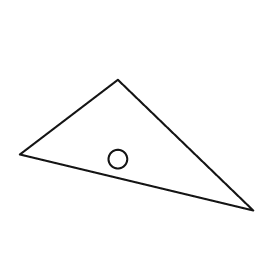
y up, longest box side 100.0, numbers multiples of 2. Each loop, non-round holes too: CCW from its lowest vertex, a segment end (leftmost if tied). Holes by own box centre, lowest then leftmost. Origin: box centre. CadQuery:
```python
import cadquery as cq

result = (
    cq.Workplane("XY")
    .moveTo(50.0, -28.0)
    .lineTo(-8.0, 28.0)
    .lineTo(-50.0, -4.0)
    .close()
    .moveTo(-8.0, -6.0)
    .circle(4.0)
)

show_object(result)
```